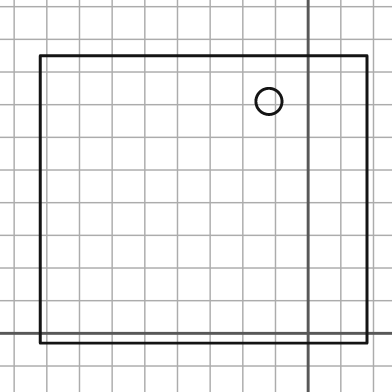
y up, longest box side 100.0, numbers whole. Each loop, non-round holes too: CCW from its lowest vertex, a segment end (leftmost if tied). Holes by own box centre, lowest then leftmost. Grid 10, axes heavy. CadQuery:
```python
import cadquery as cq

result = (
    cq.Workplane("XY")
    .moveTo(-82.0, -3.0)
    .lineTo(18.0, -3.0)
    .lineTo(18.0, 85.0)
    .lineTo(-82.0, 85.0)
    .close()
    .moveTo(-12.0, 71.0)
    .circle(4.0)
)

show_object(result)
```